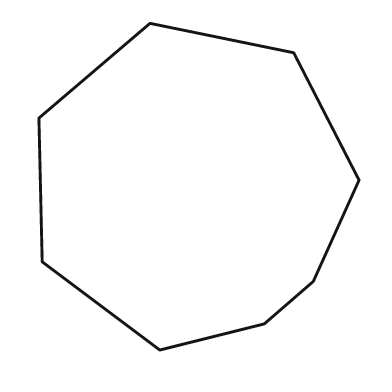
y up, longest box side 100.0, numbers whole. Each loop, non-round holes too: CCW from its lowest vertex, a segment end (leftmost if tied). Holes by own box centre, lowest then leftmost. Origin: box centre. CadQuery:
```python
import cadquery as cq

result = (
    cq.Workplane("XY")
    .moveTo(-12.0, -50.0)
    .lineTo(20.0, -42.0)
    .lineTo(35.0, -29.0)
    .lineTo(49.0, 2.0)
    .lineTo(29.0, 41.0)
    .lineTo(-15.0, 50.0)
    .lineTo(-49.0, 21.0)
    .lineTo(-48.0, -23.0)
    .close()
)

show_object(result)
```